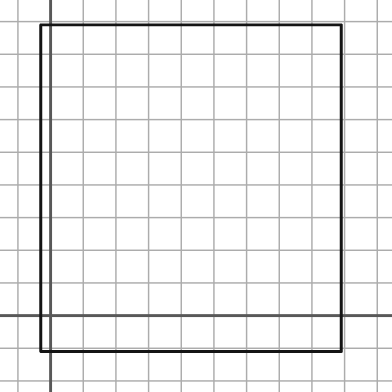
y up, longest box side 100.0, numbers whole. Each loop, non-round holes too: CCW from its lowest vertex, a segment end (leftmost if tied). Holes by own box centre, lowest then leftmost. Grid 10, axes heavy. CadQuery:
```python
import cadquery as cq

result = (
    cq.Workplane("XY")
    .moveTo(-3.0, -11.0)
    .lineTo(89.0, -11.0)
    .lineTo(89.0, 89.0)
    .lineTo(-3.0, 89.0)
    .close()
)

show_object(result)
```